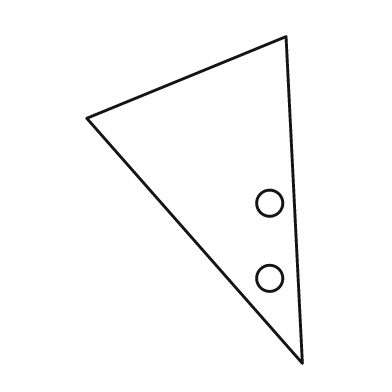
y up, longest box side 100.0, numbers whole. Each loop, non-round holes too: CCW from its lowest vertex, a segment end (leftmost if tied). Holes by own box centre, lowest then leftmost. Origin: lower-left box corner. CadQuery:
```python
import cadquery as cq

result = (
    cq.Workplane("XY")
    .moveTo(66.0, 0.0)
    .lineTo(61.0, 100.0)
    .lineTo(0.0, 75.0)
    .close()
    .moveTo(56.0, 26.0)
    .circle(4.0)
    .moveTo(56.0, 49.0)
    .circle(4.0)
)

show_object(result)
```